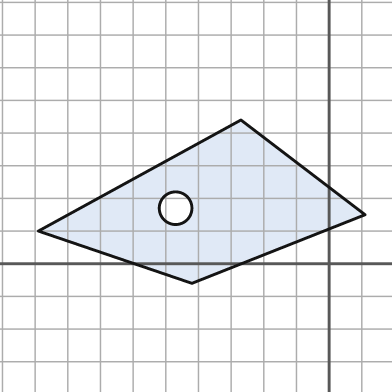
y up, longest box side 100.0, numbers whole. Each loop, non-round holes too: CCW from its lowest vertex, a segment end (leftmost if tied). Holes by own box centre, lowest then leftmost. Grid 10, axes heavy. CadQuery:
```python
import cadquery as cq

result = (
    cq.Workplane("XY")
    .moveTo(-42.0, -6.0)
    .lineTo(11.0, 15.0)
    .lineTo(-27.0, 44.0)
    .lineTo(-89.0, 10.0)
    .close()
    .moveTo(-47.0, 17.0)
    .circle(5.0)
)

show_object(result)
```